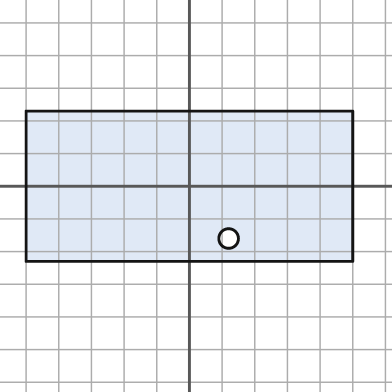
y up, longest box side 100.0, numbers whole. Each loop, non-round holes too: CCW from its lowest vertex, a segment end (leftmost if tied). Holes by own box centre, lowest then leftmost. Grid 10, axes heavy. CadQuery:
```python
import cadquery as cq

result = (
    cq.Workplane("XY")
    .moveTo(-50.0, -23.0)
    .lineTo(50.0, -23.0)
    .lineTo(50.0, 23.0)
    .lineTo(-50.0, 23.0)
    .close()
    .moveTo(12.0, -16.0)
    .circle(3.0)
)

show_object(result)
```